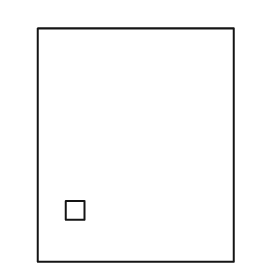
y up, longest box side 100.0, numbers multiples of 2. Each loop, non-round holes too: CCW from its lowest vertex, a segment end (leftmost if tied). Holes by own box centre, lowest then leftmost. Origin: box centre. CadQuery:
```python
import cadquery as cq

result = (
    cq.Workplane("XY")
    .moveTo(-42.0, -50.0)
    .lineTo(42.0, -50.0)
    .lineTo(42.0, 50.0)
    .lineTo(-42.0, 50.0)
    .close()
    .moveTo(-30.0, -32.0)
    .lineTo(-22.0, -32.0)
    .lineTo(-22.0, -24.0)
    .lineTo(-30.0, -24.0)
    .close()
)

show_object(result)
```